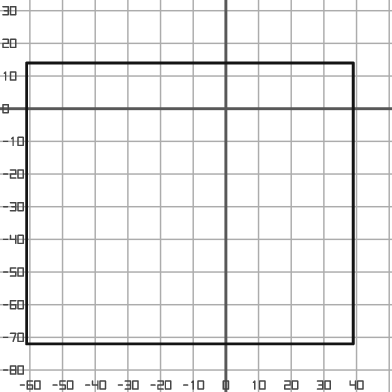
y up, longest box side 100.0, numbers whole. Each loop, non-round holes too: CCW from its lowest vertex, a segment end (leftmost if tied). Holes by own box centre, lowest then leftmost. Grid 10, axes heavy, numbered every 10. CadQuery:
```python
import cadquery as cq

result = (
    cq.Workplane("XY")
    .moveTo(-61.0, -72.0)
    .lineTo(39.0, -72.0)
    .lineTo(39.0, 14.0)
    .lineTo(-61.0, 14.0)
    .close()
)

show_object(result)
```